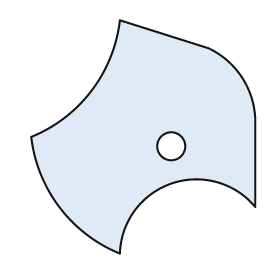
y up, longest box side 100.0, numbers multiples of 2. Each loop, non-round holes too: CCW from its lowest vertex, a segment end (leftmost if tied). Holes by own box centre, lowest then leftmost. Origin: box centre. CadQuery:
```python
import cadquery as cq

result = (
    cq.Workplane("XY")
    .moveTo(-10.0, -50.0)
    .threePointArc((12.0, -20.0), (48.0, -30.0))
    .lineTo(48.0, 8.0)
    .threePointArc((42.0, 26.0), (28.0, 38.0))
    .lineTo(-10.0, 50.0)
    .threePointArc((-22.0, 20.0), (-48.0, 0.0))
    .threePointArc((-36.0, -30.0), (-10.0, -50.0))
    .close()
    .moveTo(12.0, -4.0)
    .circle(6.0)
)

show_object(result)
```